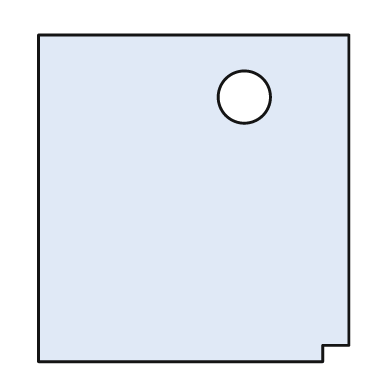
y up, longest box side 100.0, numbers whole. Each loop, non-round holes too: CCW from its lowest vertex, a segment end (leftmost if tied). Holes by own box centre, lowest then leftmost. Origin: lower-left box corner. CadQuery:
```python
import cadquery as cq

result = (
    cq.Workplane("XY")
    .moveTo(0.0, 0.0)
    .lineTo(87.0, 0.0)
    .lineTo(87.0, 5.0)
    .lineTo(95.0, 5.0)
    .lineTo(95.0, 100.0)
    .lineTo(0.0, 100.0)
    .close()
    .moveTo(63.0, 81.0)
    .circle(8.0)
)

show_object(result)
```